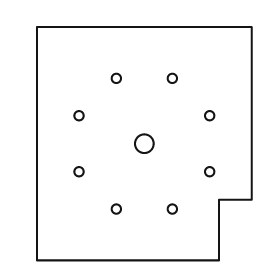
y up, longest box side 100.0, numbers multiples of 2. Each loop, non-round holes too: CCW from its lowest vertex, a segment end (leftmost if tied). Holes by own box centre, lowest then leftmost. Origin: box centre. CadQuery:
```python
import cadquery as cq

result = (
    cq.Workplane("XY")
    .moveTo(-46.0, -50.0)
    .lineTo(32.0, -50.0)
    .lineTo(32.0, -24.0)
    .lineTo(46.0, -24.0)
    .lineTo(46.0, 50.0)
    .lineTo(-46.0, 50.0)
    .close()
    .moveTo(-12.0, -28.0)
    .circle(2.0)
    .moveTo(12.0, -28.0)
    .circle(2.0)
    .moveTo(-28.0, -12.0)
    .circle(2.0)
    .moveTo(28.0, -12.0)
    .circle(2.0)
    .moveTo(0.0, 0.0)
    .circle(4.0)
    .moveTo(-28.0, 12.0)
    .circle(2.0)
    .moveTo(28.0, 12.0)
    .circle(2.0)
    .moveTo(-12.0, 28.0)
    .circle(2.0)
    .moveTo(12.0, 28.0)
    .circle(2.0)
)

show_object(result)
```